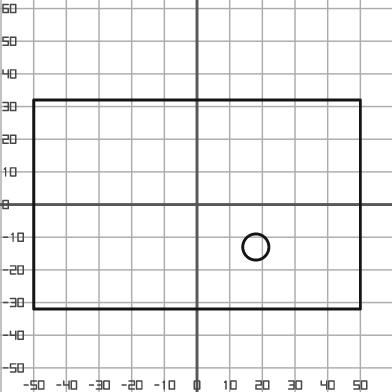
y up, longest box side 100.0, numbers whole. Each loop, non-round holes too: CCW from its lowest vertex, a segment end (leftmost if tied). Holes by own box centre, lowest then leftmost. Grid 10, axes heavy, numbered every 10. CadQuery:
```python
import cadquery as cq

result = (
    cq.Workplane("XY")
    .moveTo(-50.0, -32.0)
    .lineTo(50.0, -32.0)
    .lineTo(50.0, 32.0)
    .lineTo(-50.0, 32.0)
    .close()
    .moveTo(18.0, -13.0)
    .circle(4.0)
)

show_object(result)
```